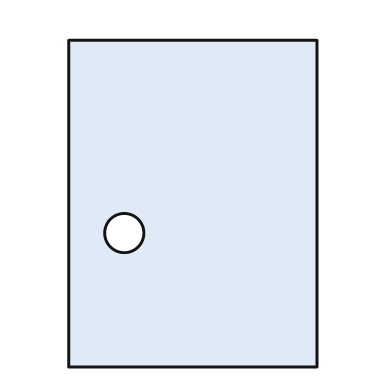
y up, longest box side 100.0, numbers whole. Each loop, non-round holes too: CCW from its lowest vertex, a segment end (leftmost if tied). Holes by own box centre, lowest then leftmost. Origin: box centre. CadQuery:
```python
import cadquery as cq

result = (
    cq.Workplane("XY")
    .moveTo(-38.0, -50.0)
    .lineTo(38.0, -50.0)
    .lineTo(38.0, 50.0)
    .lineTo(-38.0, 50.0)
    .close()
    .moveTo(-21.0, -9.0)
    .circle(6.0)
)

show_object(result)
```